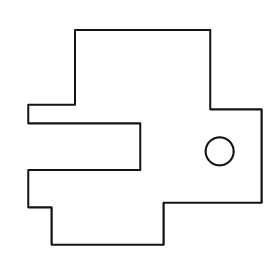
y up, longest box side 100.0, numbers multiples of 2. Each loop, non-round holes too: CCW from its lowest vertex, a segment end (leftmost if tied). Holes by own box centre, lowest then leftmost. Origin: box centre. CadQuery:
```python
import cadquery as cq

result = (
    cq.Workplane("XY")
    .moveTo(-40.0, -46.0)
    .lineTo(8.0, -46.0)
    .lineTo(8.0, -28.0)
    .lineTo(50.0, -28.0)
    .lineTo(50.0, 12.0)
    .lineTo(28.0, 12.0)
    .lineTo(28.0, 46.0)
    .lineTo(-30.0, 46.0)
    .lineTo(-30.0, 14.0)
    .lineTo(-50.0, 14.0)
    .lineTo(-50.0, 6.0)
    .lineTo(-2.0, 6.0)
    .lineTo(-2.0, -14.0)
    .lineTo(-50.0, -14.0)
    .lineTo(-50.0, -30.0)
    .lineTo(-40.0, -30.0)
    .close()
    .moveTo(32.0, -6.0)
    .circle(6.0)
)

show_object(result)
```